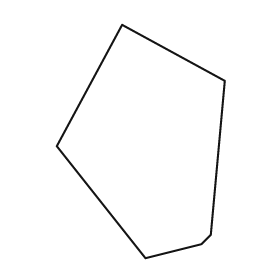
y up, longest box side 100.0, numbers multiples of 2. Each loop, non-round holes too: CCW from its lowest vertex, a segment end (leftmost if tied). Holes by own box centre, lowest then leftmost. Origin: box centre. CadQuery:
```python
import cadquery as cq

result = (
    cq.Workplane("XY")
    .moveTo(2.0, -50.0)
    .lineTo(26.0, -44.0)
    .lineTo(30.0, -40.0)
    .lineTo(36.0, 26.0)
    .lineTo(-8.0, 50.0)
    .lineTo(-36.0, -2.0)
    .close()
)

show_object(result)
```